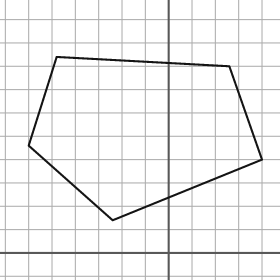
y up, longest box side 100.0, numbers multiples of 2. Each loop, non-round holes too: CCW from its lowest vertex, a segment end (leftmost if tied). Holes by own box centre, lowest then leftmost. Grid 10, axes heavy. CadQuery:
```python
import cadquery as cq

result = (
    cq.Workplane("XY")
    .moveTo(-24.0, 14.0)
    .lineTo(40.0, 40.0)
    .lineTo(26.0, 80.0)
    .lineTo(-48.0, 84.0)
    .lineTo(-60.0, 46.0)
    .close()
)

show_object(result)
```